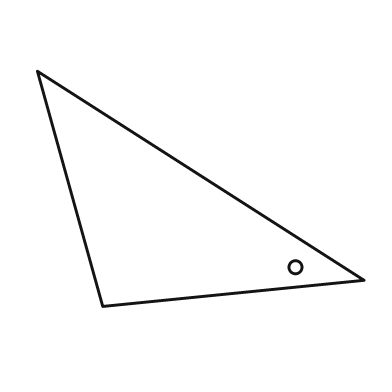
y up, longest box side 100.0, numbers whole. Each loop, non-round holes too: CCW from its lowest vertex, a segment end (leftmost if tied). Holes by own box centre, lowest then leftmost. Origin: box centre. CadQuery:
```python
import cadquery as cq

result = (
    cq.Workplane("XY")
    .moveTo(-30.0, -36.0)
    .lineTo(50.0, -28.0)
    .lineTo(-50.0, 36.0)
    .close()
    .moveTo(29.0, -24.0)
    .circle(2.0)
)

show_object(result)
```